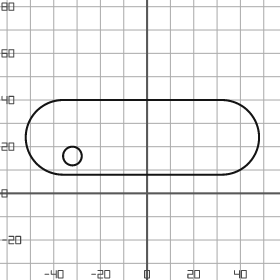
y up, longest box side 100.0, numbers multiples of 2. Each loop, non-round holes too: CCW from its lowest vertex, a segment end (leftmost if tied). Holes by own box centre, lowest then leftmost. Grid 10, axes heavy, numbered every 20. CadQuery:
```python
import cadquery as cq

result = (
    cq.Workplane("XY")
    .moveTo(-36.0, 8.0)
    .lineTo(32.0, 8.0)
    .threePointArc((48.0, 24.0), (32.0, 40.0))
    .lineTo(-36.0, 40.0)
    .threePointArc((-52.0, 24.0), (-36.0, 8.0))
    .close()
    .moveTo(-32.0, 16.0)
    .circle(4.0)
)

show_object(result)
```